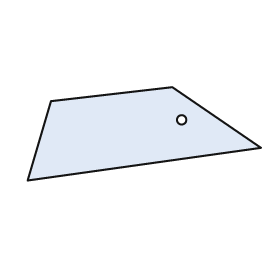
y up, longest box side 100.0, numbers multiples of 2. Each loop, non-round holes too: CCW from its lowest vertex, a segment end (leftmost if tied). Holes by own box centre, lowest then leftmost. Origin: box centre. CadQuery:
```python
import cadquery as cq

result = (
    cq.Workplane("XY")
    .moveTo(-50.0, -20.0)
    .lineTo(50.0, -6.0)
    .lineTo(12.0, 20.0)
    .lineTo(-40.0, 14.0)
    .close()
    .moveTo(16.0, 6.0)
    .circle(2.0)
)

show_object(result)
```